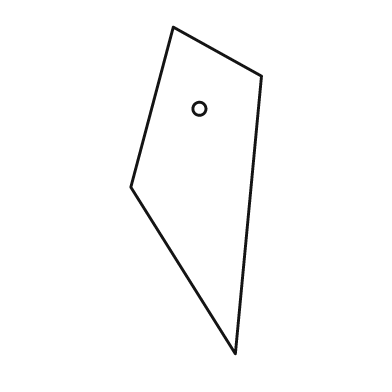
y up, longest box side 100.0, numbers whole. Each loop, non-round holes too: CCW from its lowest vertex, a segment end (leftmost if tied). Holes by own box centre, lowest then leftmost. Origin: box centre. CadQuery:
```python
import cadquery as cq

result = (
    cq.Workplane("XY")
    .moveTo(12.0, -50.0)
    .lineTo(20.0, 35.0)
    .lineTo(-7.0, 50.0)
    .lineTo(-20.0, 1.0)
    .close()
    .moveTo(1.0, 25.0)
    .circle(2.0)
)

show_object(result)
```